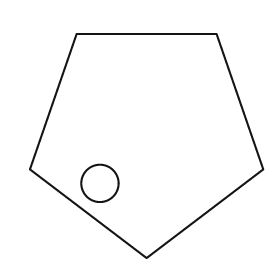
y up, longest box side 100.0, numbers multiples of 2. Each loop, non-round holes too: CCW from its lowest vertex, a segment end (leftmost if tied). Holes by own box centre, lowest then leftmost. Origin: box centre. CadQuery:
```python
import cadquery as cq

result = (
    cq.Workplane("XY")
    .moveTo(0.0, -48.0)
    .lineTo(50.0, -10.0)
    .lineTo(30.0, 48.0)
    .lineTo(-30.0, 48.0)
    .lineTo(-50.0, -10.0)
    .close()
    .moveTo(-20.0, -16.0)
    .circle(8.0)
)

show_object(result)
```